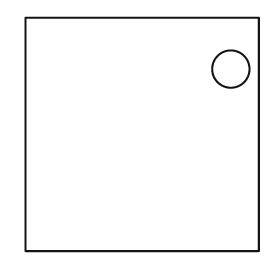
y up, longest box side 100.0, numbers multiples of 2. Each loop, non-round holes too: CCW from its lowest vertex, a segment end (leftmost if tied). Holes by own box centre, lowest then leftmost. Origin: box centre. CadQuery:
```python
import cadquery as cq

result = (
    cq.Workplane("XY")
    .moveTo(-50.0, -50.0)
    .lineTo(50.0, -50.0)
    .lineTo(50.0, 50.0)
    .lineTo(-50.0, 50.0)
    .close()
    .moveTo(38.0, 28.0)
    .circle(8.0)
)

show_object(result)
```